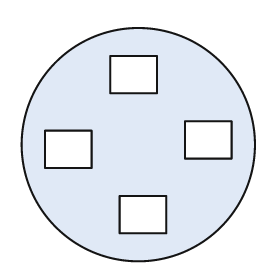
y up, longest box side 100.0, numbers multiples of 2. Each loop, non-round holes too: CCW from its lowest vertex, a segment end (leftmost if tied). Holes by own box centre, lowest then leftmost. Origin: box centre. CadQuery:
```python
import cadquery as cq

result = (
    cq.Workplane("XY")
    .moveTo(0.0, 0.0)
    .circle(50.0)
    .moveTo(-8.0, -38.0)
    .lineTo(12.0, -38.0)
    .lineTo(12.0, -22.0)
    .lineTo(-8.0, -22.0)
    .close()
    .moveTo(-40.0, -10.0)
    .lineTo(-20.0, -10.0)
    .lineTo(-20.0, 6.0)
    .lineTo(-40.0, 6.0)
    .close()
    .moveTo(20.0, -6.0)
    .lineTo(40.0, -6.0)
    .lineTo(40.0, 10.0)
    .lineTo(20.0, 10.0)
    .close()
    .moveTo(-12.0, 22.0)
    .lineTo(8.0, 22.0)
    .lineTo(8.0, 38.0)
    .lineTo(-12.0, 38.0)
    .close()
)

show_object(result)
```